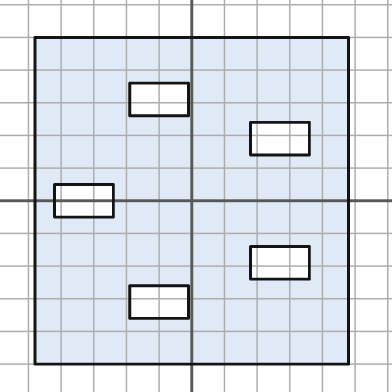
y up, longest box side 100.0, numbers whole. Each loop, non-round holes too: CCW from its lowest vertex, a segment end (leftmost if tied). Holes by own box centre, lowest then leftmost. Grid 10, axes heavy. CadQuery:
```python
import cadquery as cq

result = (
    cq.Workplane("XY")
    .moveTo(-48.0, -50.0)
    .lineTo(48.0, -50.0)
    .lineTo(48.0, 50.0)
    .lineTo(-48.0, 50.0)
    .close()
    .moveTo(-19.0, -36.0)
    .lineTo(-1.0, -36.0)
    .lineTo(-1.0, -26.0)
    .lineTo(-19.0, -26.0)
    .close()
    .moveTo(18.0, -24.0)
    .lineTo(36.0, -24.0)
    .lineTo(36.0, -14.0)
    .lineTo(18.0, -14.0)
    .close()
    .moveTo(-42.0, -5.0)
    .lineTo(-24.0, -5.0)
    .lineTo(-24.0, 5.0)
    .lineTo(-42.0, 5.0)
    .close()
    .moveTo(18.0, 14.0)
    .lineTo(36.0, 14.0)
    .lineTo(36.0, 24.0)
    .lineTo(18.0, 24.0)
    .close()
    .moveTo(-19.0, 26.0)
    .lineTo(-1.0, 26.0)
    .lineTo(-1.0, 36.0)
    .lineTo(-19.0, 36.0)
    .close()
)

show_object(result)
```